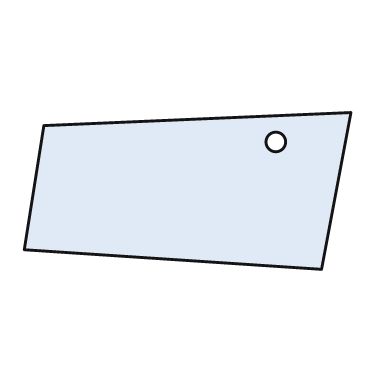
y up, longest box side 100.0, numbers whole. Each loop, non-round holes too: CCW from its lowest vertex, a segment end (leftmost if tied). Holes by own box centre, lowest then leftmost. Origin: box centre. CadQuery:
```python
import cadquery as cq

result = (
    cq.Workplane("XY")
    .moveTo(41.0, -24.0)
    .lineTo(50.0, 24.0)
    .lineTo(-44.0, 20.0)
    .lineTo(-50.0, -18.0)
    .close()
    .moveTo(27.0, 15.0)
    .circle(3.0)
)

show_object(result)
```